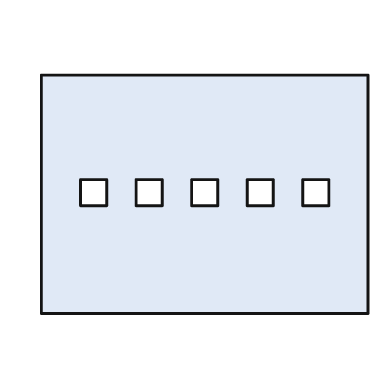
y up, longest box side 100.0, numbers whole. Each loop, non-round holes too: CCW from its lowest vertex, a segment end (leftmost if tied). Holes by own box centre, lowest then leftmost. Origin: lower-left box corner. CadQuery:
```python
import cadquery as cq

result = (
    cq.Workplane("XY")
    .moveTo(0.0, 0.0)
    .lineTo(100.0, 0.0)
    .lineTo(100.0, 73.0)
    .lineTo(0.0, 73.0)
    .close()
    .moveTo(12.0, 33.0)
    .lineTo(20.0, 33.0)
    .lineTo(20.0, 41.0)
    .lineTo(12.0, 41.0)
    .close()
    .moveTo(29.0, 33.0)
    .lineTo(37.0, 33.0)
    .lineTo(37.0, 41.0)
    .lineTo(29.0, 41.0)
    .close()
    .moveTo(46.0, 33.0)
    .lineTo(54.0, 33.0)
    .lineTo(54.0, 41.0)
    .lineTo(46.0, 41.0)
    .close()
    .moveTo(63.0, 33.0)
    .lineTo(71.0, 33.0)
    .lineTo(71.0, 41.0)
    .lineTo(63.0, 41.0)
    .close()
    .moveTo(80.0, 33.0)
    .lineTo(88.0, 33.0)
    .lineTo(88.0, 41.0)
    .lineTo(80.0, 41.0)
    .close()
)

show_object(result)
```